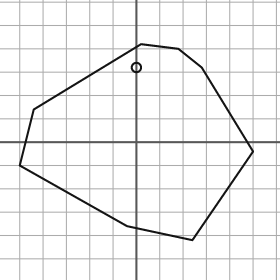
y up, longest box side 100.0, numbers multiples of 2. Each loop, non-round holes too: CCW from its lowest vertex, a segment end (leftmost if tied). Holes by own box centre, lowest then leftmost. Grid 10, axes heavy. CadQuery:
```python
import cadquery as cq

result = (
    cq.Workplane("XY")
    .moveTo(24.0, -42.0)
    .lineTo(50.0, -4.0)
    .lineTo(28.0, 32.0)
    .lineTo(18.0, 40.0)
    .lineTo(2.0, 42.0)
    .lineTo(-44.0, 14.0)
    .lineTo(-50.0, -10.0)
    .lineTo(-4.0, -36.0)
    .close()
    .moveTo(0.0, 32.0)
    .circle(2.0)
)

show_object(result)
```